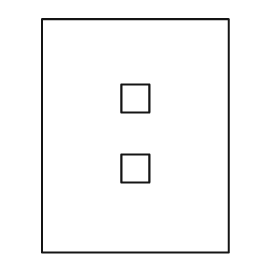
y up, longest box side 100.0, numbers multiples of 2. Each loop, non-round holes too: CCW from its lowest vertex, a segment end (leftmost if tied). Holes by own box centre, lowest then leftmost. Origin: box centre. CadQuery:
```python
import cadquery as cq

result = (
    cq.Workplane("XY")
    .moveTo(-40.0, -50.0)
    .lineTo(40.0, -50.0)
    .lineTo(40.0, 50.0)
    .lineTo(-40.0, 50.0)
    .close()
    .moveTo(-6.0, -20.0)
    .lineTo(6.0, -20.0)
    .lineTo(6.0, -8.0)
    .lineTo(-6.0, -8.0)
    .close()
    .moveTo(-6.0, 10.0)
    .lineTo(6.0, 10.0)
    .lineTo(6.0, 22.0)
    .lineTo(-6.0, 22.0)
    .close()
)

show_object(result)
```